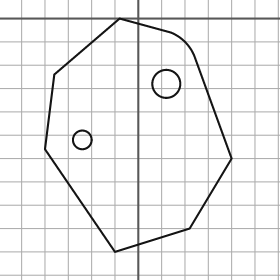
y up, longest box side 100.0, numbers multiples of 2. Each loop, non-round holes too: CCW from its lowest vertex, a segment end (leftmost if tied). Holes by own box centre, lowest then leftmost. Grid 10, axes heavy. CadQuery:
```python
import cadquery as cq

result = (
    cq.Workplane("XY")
    .moveTo(-10.0, -100.0)
    .lineTo(22.0, -90.0)
    .lineTo(40.0, -60.0)
    .lineTo(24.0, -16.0)
    .threePointArc((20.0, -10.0), (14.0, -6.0))
    .lineTo(-8.0, 0.0)
    .lineTo(-36.0, -24.0)
    .lineTo(-40.0, -56.0)
    .close()
    .moveTo(-24.0, -52.0)
    .circle(4.0)
    .moveTo(12.0, -28.0)
    .circle(6.0)
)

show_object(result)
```